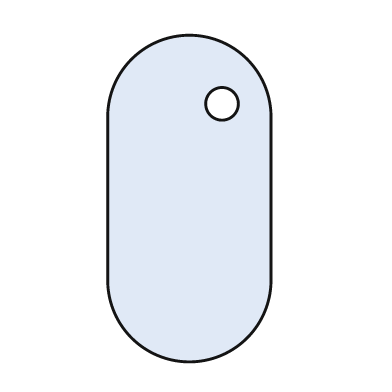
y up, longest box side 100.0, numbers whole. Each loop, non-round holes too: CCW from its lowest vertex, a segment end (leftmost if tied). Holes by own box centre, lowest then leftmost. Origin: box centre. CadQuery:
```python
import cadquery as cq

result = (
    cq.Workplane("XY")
    .moveTo(-25.0, -25.0)
    .threePointArc((0.0, -50.0), (25.0, -25.0))
    .lineTo(25.0, 25.0)
    .threePointArc((0.0, 50.0), (-25.0, 25.0))
    .close()
    .moveTo(10.0, 29.0)
    .circle(5.0)
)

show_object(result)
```